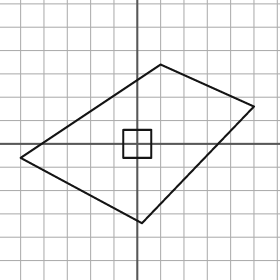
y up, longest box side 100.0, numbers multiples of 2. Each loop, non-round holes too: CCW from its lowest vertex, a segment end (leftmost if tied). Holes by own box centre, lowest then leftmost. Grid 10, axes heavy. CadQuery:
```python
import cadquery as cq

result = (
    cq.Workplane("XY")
    .moveTo(2.0, -34.0)
    .lineTo(50.0, 16.0)
    .lineTo(10.0, 34.0)
    .lineTo(-50.0, -6.0)
    .close()
    .moveTo(-6.0, -6.0)
    .lineTo(6.0, -6.0)
    .lineTo(6.0, 6.0)
    .lineTo(-6.0, 6.0)
    .close()
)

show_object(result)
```